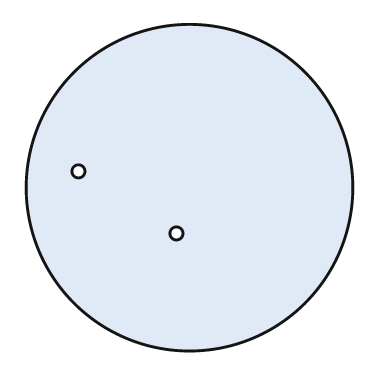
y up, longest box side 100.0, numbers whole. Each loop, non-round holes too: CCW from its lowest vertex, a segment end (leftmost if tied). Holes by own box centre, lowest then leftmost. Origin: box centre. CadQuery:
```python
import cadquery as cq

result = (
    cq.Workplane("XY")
    .moveTo(0.0, 0.0)
    .circle(50.0)
    .moveTo(-4.0, -14.0)
    .circle(2.0)
    .moveTo(-34.0, 5.0)
    .circle(2.0)
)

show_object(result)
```